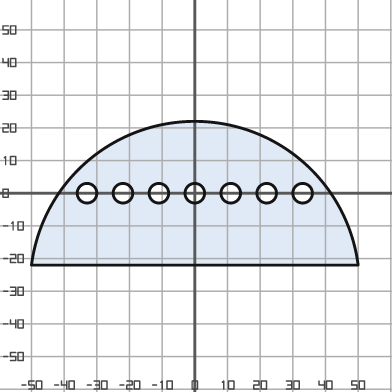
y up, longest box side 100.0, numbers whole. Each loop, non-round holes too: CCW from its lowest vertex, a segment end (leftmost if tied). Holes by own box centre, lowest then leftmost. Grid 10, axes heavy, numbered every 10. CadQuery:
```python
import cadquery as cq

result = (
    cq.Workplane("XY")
    .moveTo(-50.0, -22.0)
    .lineTo(50.0, -22.0)
    .threePointArc((0.0, 22.0), (-50.0, -22.0))
    .close()
    .moveTo(-33.0, 0.0)
    .circle(3.0)
    .moveTo(-22.0, 0.0)
    .circle(3.0)
    .moveTo(-11.0, 0.0)
    .circle(3.0)
    .moveTo(0.0, 0.0)
    .circle(3.0)
    .moveTo(11.0, 0.0)
    .circle(3.0)
    .moveTo(22.0, 0.0)
    .circle(3.0)
    .moveTo(33.0, 0.0)
    .circle(3.0)
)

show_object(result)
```